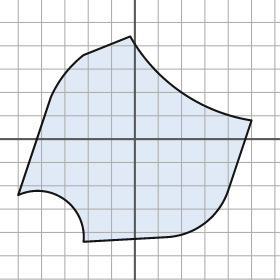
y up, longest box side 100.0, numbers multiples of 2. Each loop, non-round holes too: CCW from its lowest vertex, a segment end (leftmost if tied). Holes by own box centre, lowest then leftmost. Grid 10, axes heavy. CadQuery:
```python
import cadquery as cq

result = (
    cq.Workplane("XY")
    .moveTo(-22.0, -44.0)
    .lineTo(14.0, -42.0)
    .threePointArc((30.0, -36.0), (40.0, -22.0))
    .lineTo(50.0, 8.0)
    .threePointArc((20.0, 20.0), (-2.0, 44.0))
    .lineTo(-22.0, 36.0)
    .threePointArc((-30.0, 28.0), (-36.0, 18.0))
    .lineTo(-50.0, -24.0)
    .threePointArc((-30.0, -26.0), (-22.0, -44.0))
    .close()
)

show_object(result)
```